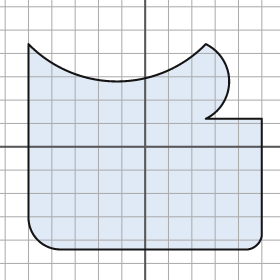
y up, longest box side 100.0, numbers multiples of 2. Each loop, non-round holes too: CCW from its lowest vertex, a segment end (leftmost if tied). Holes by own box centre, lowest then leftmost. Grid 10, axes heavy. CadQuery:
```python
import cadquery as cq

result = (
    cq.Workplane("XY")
    .moveTo(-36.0, -44.0)
    .lineTo(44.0, -44.0)
    .threePointArc((48.0, -42.0), (50.0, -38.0))
    .lineTo(50.0, 12.0)
    .lineTo(26.0, 12.0)
    .threePointArc((36.0, 28.0), (26.0, 44.0))
    .threePointArc((-12.0, 28.0), (-50.0, 44.0))
    .lineTo(-50.0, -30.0)
    .threePointArc((-46.0, -40.0), (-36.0, -44.0))
    .close()
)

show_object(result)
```